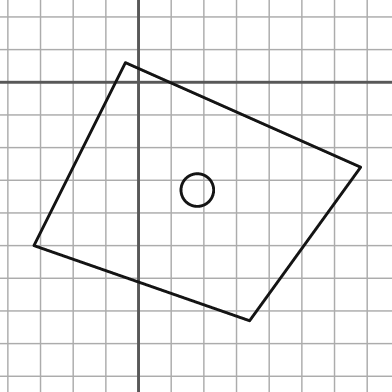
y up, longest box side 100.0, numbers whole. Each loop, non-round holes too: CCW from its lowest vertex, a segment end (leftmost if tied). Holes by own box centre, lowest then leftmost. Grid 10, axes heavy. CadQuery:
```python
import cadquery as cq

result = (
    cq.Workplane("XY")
    .moveTo(34.0, -73.0)
    .lineTo(68.0, -26.0)
    .lineTo(-4.0, 6.0)
    .lineTo(-32.0, -50.0)
    .close()
    .moveTo(18.0, -33.0)
    .circle(5.0)
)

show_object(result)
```